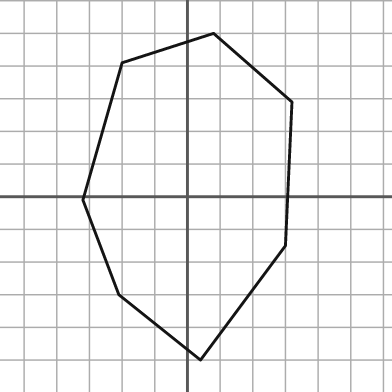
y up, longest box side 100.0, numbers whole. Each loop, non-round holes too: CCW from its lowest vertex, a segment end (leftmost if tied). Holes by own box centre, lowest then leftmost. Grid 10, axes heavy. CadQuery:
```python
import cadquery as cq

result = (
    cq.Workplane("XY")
    .moveTo(4.0, -50.0)
    .lineTo(30.0, -15.0)
    .lineTo(32.0, 29.0)
    .lineTo(8.0, 50.0)
    .lineTo(-20.0, 41.0)
    .lineTo(-32.0, -1.0)
    .lineTo(-21.0, -30.0)
    .close()
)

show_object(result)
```